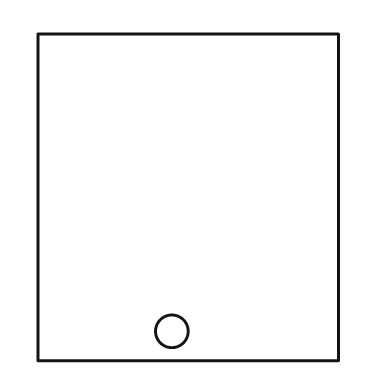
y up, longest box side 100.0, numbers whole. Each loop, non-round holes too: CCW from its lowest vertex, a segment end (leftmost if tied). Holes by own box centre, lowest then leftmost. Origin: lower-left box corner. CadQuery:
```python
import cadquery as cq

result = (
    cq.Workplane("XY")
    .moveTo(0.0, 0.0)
    .lineTo(92.0, 0.0)
    .lineTo(92.0, 100.0)
    .lineTo(0.0, 100.0)
    .close()
    .moveTo(41.0, 9.0)
    .circle(5.0)
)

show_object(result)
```